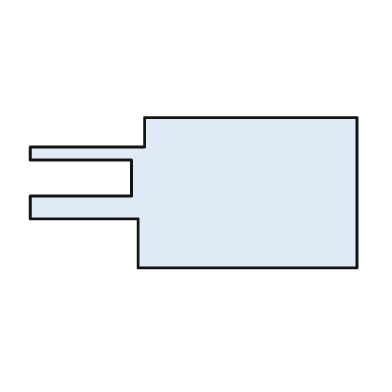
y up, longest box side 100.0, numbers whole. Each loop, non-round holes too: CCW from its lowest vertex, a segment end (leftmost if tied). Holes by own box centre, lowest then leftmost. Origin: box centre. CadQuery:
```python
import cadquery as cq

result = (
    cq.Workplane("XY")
    .moveTo(-17.0, -23.0)
    .lineTo(50.0, -23.0)
    .lineTo(50.0, 23.0)
    .lineTo(-15.0, 23.0)
    .lineTo(-15.0, 14.0)
    .lineTo(-50.0, 14.0)
    .lineTo(-50.0, 10.0)
    .lineTo(-19.0, 10.0)
    .lineTo(-19.0, -1.0)
    .lineTo(-50.0, -1.0)
    .lineTo(-50.0, -8.0)
    .lineTo(-17.0, -8.0)
    .close()
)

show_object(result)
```